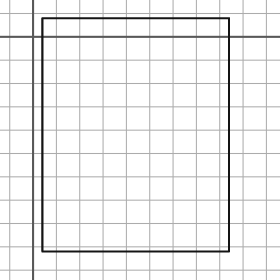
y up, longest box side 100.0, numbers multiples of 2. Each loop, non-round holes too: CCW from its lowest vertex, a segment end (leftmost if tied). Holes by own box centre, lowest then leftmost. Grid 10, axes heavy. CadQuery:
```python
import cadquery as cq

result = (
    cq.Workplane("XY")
    .moveTo(4.0, -92.0)
    .lineTo(84.0, -92.0)
    .lineTo(84.0, 8.0)
    .lineTo(4.0, 8.0)
    .close()
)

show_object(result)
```